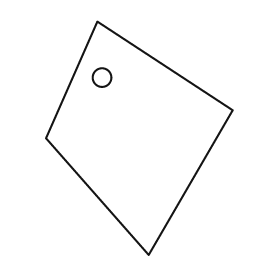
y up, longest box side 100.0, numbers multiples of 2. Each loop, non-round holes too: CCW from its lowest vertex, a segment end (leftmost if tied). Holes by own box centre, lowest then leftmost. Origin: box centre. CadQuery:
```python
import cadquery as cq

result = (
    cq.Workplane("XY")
    .moveTo(4.0, -50.0)
    .lineTo(40.0, 12.0)
    .lineTo(-18.0, 50.0)
    .lineTo(-40.0, 0.0)
    .close()
    .moveTo(-16.0, 26.0)
    .circle(4.0)
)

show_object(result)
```